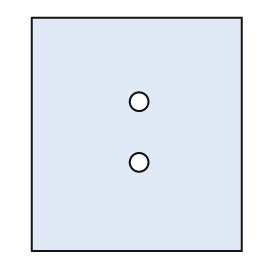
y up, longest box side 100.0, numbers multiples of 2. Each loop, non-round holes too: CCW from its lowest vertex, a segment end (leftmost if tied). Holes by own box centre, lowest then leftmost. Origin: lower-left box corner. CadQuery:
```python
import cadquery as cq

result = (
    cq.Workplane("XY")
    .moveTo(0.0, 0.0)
    .lineTo(90.0, 0.0)
    .lineTo(90.0, 100.0)
    .lineTo(0.0, 100.0)
    .close()
    .moveTo(46.0, 38.0)
    .circle(4.0)
    .moveTo(46.0, 64.0)
    .circle(4.0)
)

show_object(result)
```